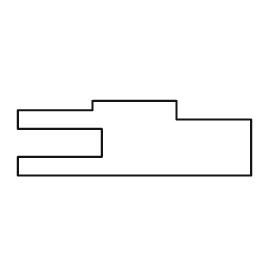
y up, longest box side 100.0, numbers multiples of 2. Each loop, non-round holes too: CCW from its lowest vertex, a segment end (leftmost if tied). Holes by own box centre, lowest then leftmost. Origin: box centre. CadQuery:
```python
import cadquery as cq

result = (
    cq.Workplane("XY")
    .moveTo(-50.0, -16.0)
    .lineTo(50.0, -16.0)
    .lineTo(50.0, 8.0)
    .lineTo(18.0, 8.0)
    .lineTo(18.0, 16.0)
    .lineTo(-18.0, 16.0)
    .lineTo(-18.0, 12.0)
    .lineTo(-50.0, 12.0)
    .lineTo(-50.0, 4.0)
    .lineTo(-14.0, 4.0)
    .lineTo(-14.0, -8.0)
    .lineTo(-50.0, -8.0)
    .close()
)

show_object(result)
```